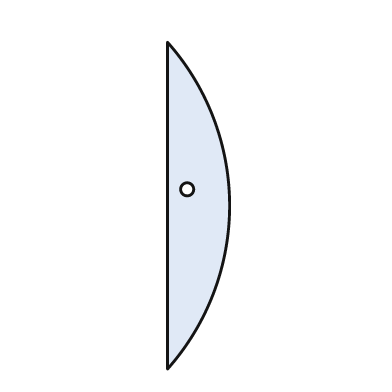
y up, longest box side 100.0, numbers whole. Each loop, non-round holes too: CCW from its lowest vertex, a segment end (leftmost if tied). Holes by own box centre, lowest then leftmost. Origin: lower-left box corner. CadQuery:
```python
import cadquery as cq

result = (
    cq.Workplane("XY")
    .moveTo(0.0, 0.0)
    .threePointArc((19.0, 50.0), (0.0, 100.0))
    .close()
    .moveTo(6.0, 55.0)
    .circle(2.0)
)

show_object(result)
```